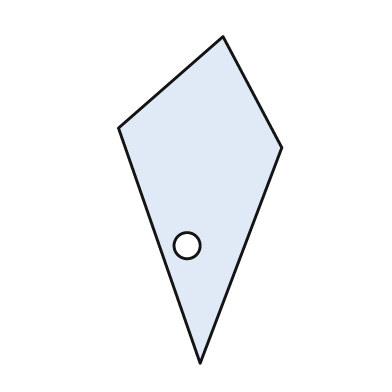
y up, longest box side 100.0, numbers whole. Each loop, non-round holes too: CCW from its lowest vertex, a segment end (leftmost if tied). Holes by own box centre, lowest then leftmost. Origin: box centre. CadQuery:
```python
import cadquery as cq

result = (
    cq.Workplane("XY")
    .moveTo(0.0, -50.0)
    .lineTo(25.0, 16.0)
    .lineTo(7.0, 50.0)
    .lineTo(-25.0, 22.0)
    .close()
    .moveTo(-4.0, -14.0)
    .circle(4.0)
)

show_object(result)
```